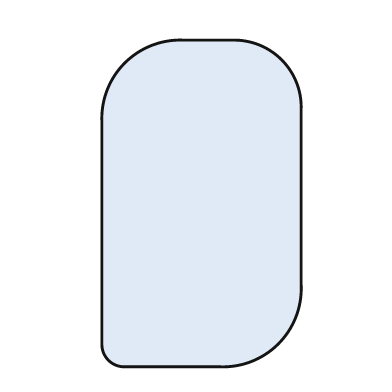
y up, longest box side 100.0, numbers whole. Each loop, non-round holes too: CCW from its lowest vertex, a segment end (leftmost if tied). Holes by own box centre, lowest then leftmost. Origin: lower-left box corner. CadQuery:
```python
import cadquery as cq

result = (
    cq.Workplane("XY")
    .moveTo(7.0, 0.0)
    .lineTo(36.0, 0.0)
    .threePointArc((54.0, 7.0), (61.0, 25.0))
    .lineTo(61.0, 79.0)
    .threePointArc((55.0, 94.0), (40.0, 100.0))
    .lineTo(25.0, 100.0)
    .threePointArc((7.0, 93.0), (0.0, 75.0))
    .lineTo(0.0, 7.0)
    .threePointArc((2.0, 2.0), (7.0, 0.0))
    .close()
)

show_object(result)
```